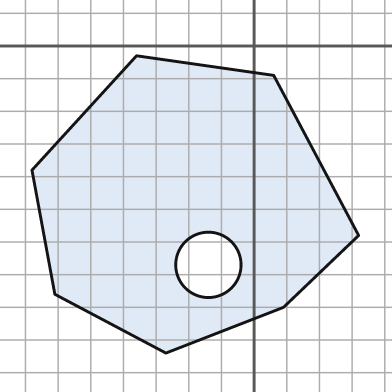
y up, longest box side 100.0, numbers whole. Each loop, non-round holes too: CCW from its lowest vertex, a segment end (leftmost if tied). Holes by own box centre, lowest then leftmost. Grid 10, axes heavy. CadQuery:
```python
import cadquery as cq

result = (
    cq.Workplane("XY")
    .moveTo(-27.0, -94.0)
    .lineTo(9.0, -80.0)
    .lineTo(32.0, -58.0)
    .lineTo(6.0, -9.0)
    .lineTo(-36.0, -3.0)
    .lineTo(-68.0, -38.0)
    .lineTo(-61.0, -76.0)
    .close()
    .moveTo(-14.0, -67.0)
    .circle(10.0)
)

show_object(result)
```